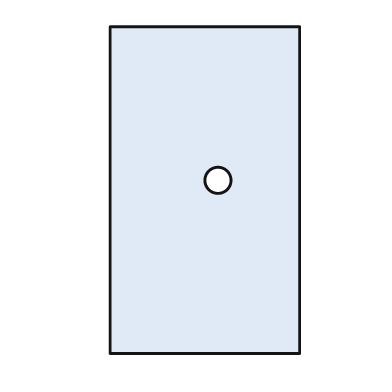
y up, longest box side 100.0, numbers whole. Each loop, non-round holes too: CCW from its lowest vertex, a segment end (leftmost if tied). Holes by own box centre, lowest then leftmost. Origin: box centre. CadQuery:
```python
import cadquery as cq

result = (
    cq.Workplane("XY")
    .moveTo(-29.0, -50.0)
    .lineTo(29.0, -50.0)
    .lineTo(29.0, 50.0)
    .lineTo(-29.0, 50.0)
    .close()
    .moveTo(4.0, 3.0)
    .circle(4.0)
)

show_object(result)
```